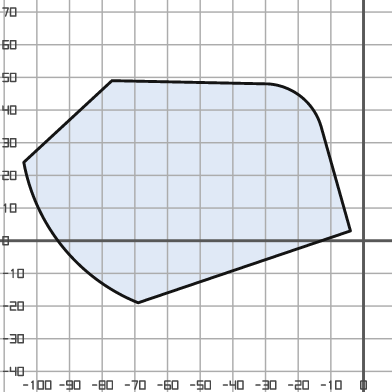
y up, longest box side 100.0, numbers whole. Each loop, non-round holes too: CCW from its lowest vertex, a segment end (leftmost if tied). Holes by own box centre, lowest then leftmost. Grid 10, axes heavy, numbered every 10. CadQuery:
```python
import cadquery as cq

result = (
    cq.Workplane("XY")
    .moveTo(-69.0, -19.0)
    .lineTo(-4.0, 3.0)
    .lineTo(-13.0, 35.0)
    .threePointArc((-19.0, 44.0), (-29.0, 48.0))
    .lineTo(-77.0, 49.0)
    .lineTo(-104.0, 24.0)
    .threePointArc((-92.0, -2.0), (-69.0, -19.0))
    .close()
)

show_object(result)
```